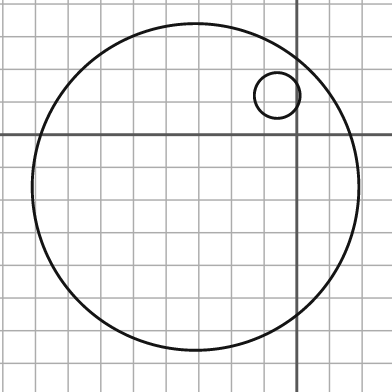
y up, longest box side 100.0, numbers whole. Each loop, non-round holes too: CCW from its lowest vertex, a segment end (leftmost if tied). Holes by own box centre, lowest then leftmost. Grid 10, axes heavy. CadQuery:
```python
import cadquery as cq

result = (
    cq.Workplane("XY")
    .moveTo(-31.0, -16.0)
    .circle(50.0)
    .moveTo(-6.0, 12.0)
    .circle(7.0)
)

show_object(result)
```